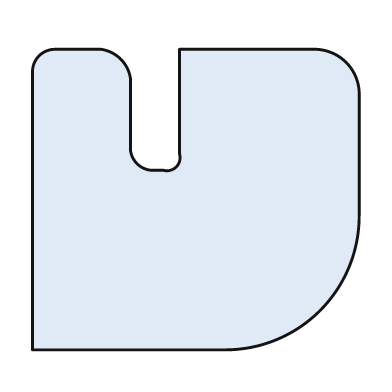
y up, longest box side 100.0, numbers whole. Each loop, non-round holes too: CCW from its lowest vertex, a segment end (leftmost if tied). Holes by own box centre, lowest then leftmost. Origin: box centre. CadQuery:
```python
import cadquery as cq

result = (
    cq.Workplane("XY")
    .moveTo(-50.0, -46.0)
    .lineTo(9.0, -46.0)
    .threePointArc((38.0, -34.0), (50.0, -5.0))
    .lineTo(50.0, 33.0)
    .threePointArc((46.0, 42.0), (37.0, 46.0))
    .lineTo(-5.0, 46.0)
    .lineTo(-5.0, 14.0)
    .threePointArc((-6.0, 10.0), (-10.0, 9.0))
    .lineTo(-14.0, 9.0)
    .threePointArc((-18.0, 11.0), (-20.0, 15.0))
    .lineTo(-20.0, 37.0)
    .threePointArc((-23.0, 43.0), (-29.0, 46.0))
    .lineTo(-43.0, 46.0)
    .threePointArc((-48.0, 44.0), (-50.0, 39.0))
    .close()
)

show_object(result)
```